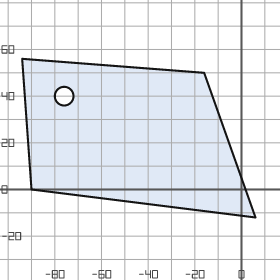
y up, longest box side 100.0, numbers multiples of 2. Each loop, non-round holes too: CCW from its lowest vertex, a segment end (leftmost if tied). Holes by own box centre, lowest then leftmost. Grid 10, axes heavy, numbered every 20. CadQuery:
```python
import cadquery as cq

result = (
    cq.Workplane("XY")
    .moveTo(6.0, -12.0)
    .lineTo(-16.0, 50.0)
    .lineTo(-94.0, 56.0)
    .lineTo(-90.0, 0.0)
    .close()
    .moveTo(-76.0, 40.0)
    .circle(4.0)
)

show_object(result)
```